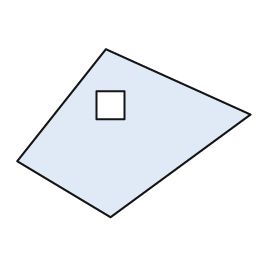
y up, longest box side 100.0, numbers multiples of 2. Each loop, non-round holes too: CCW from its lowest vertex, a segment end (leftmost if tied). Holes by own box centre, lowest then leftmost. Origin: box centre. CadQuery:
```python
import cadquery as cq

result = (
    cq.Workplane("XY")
    .moveTo(-10.0, -36.0)
    .lineTo(50.0, 8.0)
    .lineTo(-12.0, 36.0)
    .lineTo(-50.0, -12.0)
    .close()
    .moveTo(-16.0, 6.0)
    .lineTo(-4.0, 6.0)
    .lineTo(-4.0, 18.0)
    .lineTo(-16.0, 18.0)
    .close()
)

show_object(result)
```